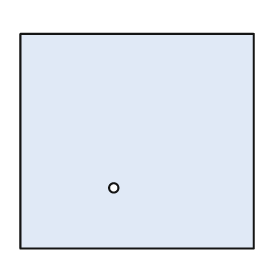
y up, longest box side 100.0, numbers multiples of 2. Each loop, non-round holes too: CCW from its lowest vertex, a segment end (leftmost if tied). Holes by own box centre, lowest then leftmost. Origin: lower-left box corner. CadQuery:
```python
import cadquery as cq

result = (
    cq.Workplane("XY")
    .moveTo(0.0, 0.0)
    .lineTo(100.0, 0.0)
    .lineTo(100.0, 92.0)
    .lineTo(0.0, 92.0)
    .close()
    .moveTo(40.0, 26.0)
    .circle(2.0)
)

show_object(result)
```